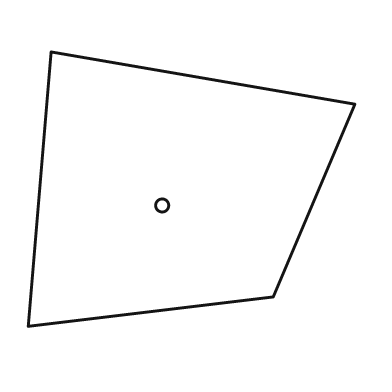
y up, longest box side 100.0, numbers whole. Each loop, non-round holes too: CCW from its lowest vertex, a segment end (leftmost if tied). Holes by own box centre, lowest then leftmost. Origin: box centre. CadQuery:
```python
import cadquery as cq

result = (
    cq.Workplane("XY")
    .moveTo(-50.0, -42.0)
    .lineTo(25.0, -33.0)
    .lineTo(50.0, 26.0)
    .lineTo(-43.0, 42.0)
    .close()
    .moveTo(-9.0, -5.0)
    .circle(2.0)
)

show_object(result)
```